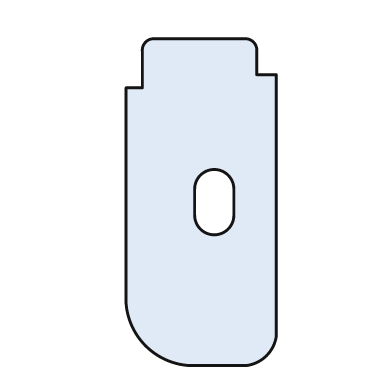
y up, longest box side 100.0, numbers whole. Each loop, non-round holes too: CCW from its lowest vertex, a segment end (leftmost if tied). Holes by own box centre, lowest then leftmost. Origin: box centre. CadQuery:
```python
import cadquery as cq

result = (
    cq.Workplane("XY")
    .moveTo(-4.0, -50.0)
    .lineTo(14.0, -50.0)
    .threePointArc((20.0, -47.0), (23.0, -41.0))
    .lineTo(23.0, 39.0)
    .lineTo(17.0, 39.0)
    .lineTo(17.0, 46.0)
    .threePointArc((16.0, 49.0), (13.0, 50.0))
    .lineTo(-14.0, 50.0)
    .threePointArc((-17.0, 49.0), (-18.0, 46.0))
    .lineTo(-18.0, 35.0)
    .lineTo(-23.0, 35.0)
    .lineTo(-23.0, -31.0)
    .threePointArc((-17.0, -44.0), (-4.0, -50.0))
    .close()
    .moveTo(-2.0, -4.0)
    .threePointArc((4.0, -10.0), (10.0, -4.0))
    .lineTo(10.0, 4.0)
    .threePointArc((4.0, 10.0), (-2.0, 4.0))
    .close()
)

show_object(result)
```